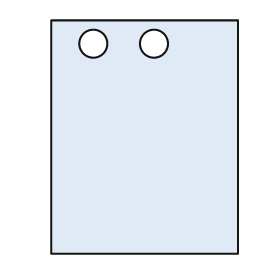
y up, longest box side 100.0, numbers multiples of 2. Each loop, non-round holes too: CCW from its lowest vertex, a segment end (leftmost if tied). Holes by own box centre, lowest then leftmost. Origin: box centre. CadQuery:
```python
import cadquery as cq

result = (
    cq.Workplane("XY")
    .moveTo(-40.0, -50.0)
    .lineTo(40.0, -50.0)
    .lineTo(40.0, 50.0)
    .lineTo(-40.0, 50.0)
    .close()
    .moveTo(-22.0, 40.0)
    .circle(6.0)
    .moveTo(4.0, 40.0)
    .circle(6.0)
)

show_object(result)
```